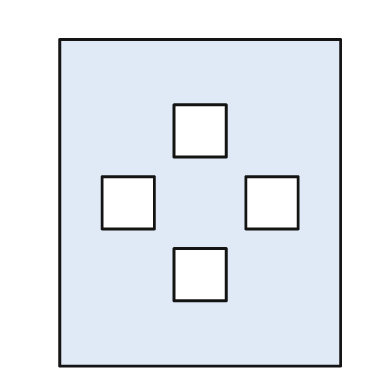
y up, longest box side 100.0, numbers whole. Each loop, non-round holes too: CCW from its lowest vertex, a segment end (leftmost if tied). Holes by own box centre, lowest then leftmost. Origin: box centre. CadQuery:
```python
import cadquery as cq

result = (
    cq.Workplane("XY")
    .moveTo(-43.0, -50.0)
    .lineTo(43.0, -50.0)
    .lineTo(43.0, 50.0)
    .lineTo(-43.0, 50.0)
    .close()
    .moveTo(-8.0, -30.0)
    .lineTo(8.0, -30.0)
    .lineTo(8.0, -14.0)
    .lineTo(-8.0, -14.0)
    .close()
    .moveTo(-30.0, -8.0)
    .lineTo(-14.0, -8.0)
    .lineTo(-14.0, 8.0)
    .lineTo(-30.0, 8.0)
    .close()
    .moveTo(14.0, -8.0)
    .lineTo(30.0, -8.0)
    .lineTo(30.0, 8.0)
    .lineTo(14.0, 8.0)
    .close()
    .moveTo(-8.0, 14.0)
    .lineTo(8.0, 14.0)
    .lineTo(8.0, 30.0)
    .lineTo(-8.0, 30.0)
    .close()
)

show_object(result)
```